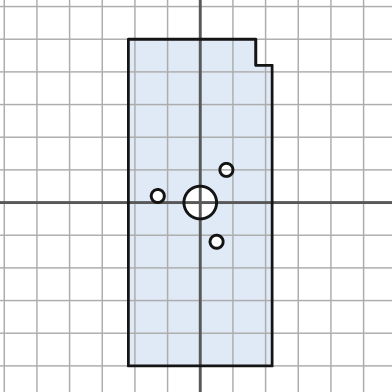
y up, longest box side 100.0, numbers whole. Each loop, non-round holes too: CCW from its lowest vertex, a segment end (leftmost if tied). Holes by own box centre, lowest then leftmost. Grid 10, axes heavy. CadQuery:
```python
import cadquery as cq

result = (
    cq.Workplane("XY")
    .moveTo(-22.0, -50.0)
    .lineTo(22.0, -50.0)
    .lineTo(22.0, 42.0)
    .lineTo(17.0, 42.0)
    .lineTo(17.0, 50.0)
    .lineTo(-22.0, 50.0)
    .close()
    .moveTo(5.0, -12.0)
    .circle(2.0)
    .moveTo(0.0, 0.0)
    .circle(5.0)
    .moveTo(-13.0, 2.0)
    .circle(2.0)
    .moveTo(8.0, 10.0)
    .circle(2.0)
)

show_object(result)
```